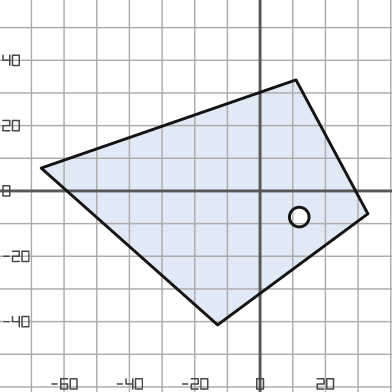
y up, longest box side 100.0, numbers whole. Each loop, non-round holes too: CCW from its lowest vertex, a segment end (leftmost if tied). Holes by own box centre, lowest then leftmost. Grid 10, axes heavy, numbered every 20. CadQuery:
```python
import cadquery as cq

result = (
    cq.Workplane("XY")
    .moveTo(-13.0, -41.0)
    .lineTo(33.0, -7.0)
    .lineTo(11.0, 34.0)
    .lineTo(-67.0, 7.0)
    .close()
    .moveTo(12.0, -8.0)
    .circle(3.0)
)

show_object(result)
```